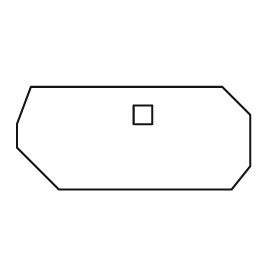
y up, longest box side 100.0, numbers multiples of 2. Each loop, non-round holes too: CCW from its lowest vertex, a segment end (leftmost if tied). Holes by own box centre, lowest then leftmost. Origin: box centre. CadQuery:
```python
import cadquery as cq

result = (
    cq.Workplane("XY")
    .moveTo(-32.0, -22.0)
    .lineTo(42.0, -22.0)
    .lineTo(50.0, -12.0)
    .lineTo(50.0, 10.0)
    .lineTo(38.0, 22.0)
    .lineTo(-44.0, 22.0)
    .lineTo(-50.0, 6.0)
    .lineTo(-50.0, -4.0)
    .close()
    .moveTo(0.0, 6.0)
    .lineTo(8.0, 6.0)
    .lineTo(8.0, 14.0)
    .lineTo(0.0, 14.0)
    .close()
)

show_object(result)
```